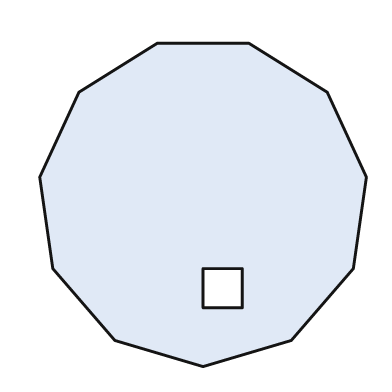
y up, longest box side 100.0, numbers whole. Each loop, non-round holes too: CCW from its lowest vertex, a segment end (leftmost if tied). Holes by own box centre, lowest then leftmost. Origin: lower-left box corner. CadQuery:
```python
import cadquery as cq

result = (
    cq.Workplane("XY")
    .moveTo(50.0, 0.0)
    .lineTo(77.0, 8.0)
    .lineTo(96.0, 30.0)
    .lineTo(100.0, 58.0)
    .lineTo(88.0, 84.0)
    .lineTo(64.0, 99.0)
    .lineTo(36.0, 99.0)
    .lineTo(12.0, 84.0)
    .lineTo(0.0, 58.0)
    .lineTo(4.0, 30.0)
    .lineTo(23.0, 8.0)
    .close()
    .moveTo(50.0, 18.0)
    .lineTo(62.0, 18.0)
    .lineTo(62.0, 30.0)
    .lineTo(50.0, 30.0)
    .close()
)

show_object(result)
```